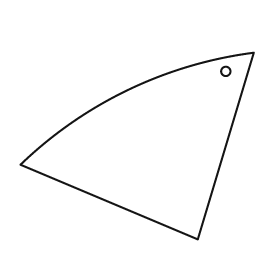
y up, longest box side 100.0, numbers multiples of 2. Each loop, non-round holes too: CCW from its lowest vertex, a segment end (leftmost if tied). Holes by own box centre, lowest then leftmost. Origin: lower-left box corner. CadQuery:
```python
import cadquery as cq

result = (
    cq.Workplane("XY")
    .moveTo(76.0, 0.0)
    .lineTo(100.0, 80.0)
    .threePointArc((46.0, 64.0), (0.0, 32.0))
    .close()
    .moveTo(88.0, 72.0)
    .circle(2.0)
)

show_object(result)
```